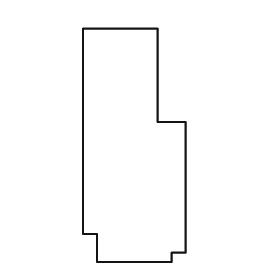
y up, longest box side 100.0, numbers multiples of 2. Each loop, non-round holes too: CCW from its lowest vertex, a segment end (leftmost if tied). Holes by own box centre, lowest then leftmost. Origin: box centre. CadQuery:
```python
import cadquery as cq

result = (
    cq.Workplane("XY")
    .moveTo(-16.0, -50.0)
    .lineTo(16.0, -50.0)
    .lineTo(16.0, -46.0)
    .lineTo(22.0, -46.0)
    .lineTo(22.0, 10.0)
    .lineTo(10.0, 10.0)
    .lineTo(10.0, 50.0)
    .lineTo(-22.0, 50.0)
    .lineTo(-22.0, -38.0)
    .lineTo(-16.0, -38.0)
    .close()
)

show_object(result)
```